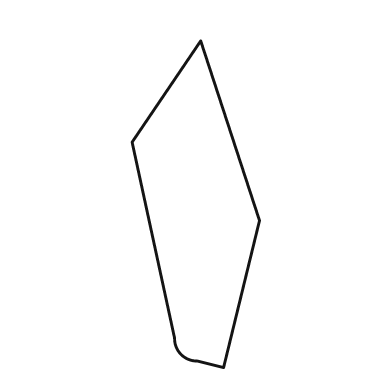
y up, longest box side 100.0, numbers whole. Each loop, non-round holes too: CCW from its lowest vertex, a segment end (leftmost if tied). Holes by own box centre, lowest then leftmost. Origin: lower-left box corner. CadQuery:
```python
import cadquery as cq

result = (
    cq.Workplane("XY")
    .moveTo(28.0, 0.0)
    .lineTo(39.0, 45.0)
    .lineTo(21.0, 100.0)
    .lineTo(0.0, 69.0)
    .lineTo(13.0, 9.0)
    .threePointArc((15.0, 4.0), (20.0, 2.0))
    .close()
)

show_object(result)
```